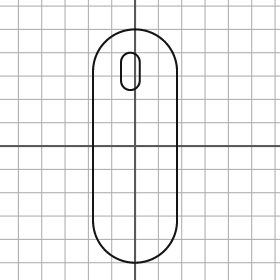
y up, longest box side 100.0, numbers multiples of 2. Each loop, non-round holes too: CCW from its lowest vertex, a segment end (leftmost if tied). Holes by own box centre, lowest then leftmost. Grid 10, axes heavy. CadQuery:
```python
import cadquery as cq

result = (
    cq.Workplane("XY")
    .moveTo(-18.0, -32.0)
    .threePointArc((0.0, -50.0), (18.0, -32.0))
    .lineTo(18.0, 32.0)
    .threePointArc((0.0, 50.0), (-18.0, 32.0))
    .close()
    .moveTo(-6.0, 28.0)
    .threePointArc((-2.0, 24.0), (2.0, 28.0))
    .lineTo(2.0, 36.0)
    .threePointArc((-2.0, 40.0), (-6.0, 36.0))
    .close()
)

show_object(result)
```